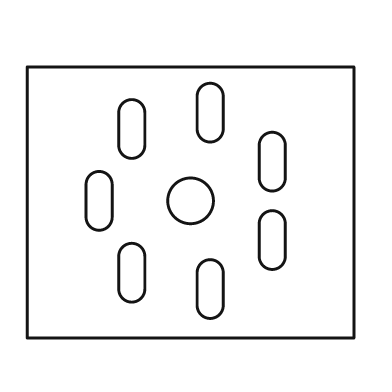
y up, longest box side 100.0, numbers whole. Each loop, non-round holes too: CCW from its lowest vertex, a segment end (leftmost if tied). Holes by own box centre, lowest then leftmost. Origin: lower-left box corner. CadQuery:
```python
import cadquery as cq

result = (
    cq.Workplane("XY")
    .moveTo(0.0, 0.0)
    .lineTo(100.0, 0.0)
    .lineTo(100.0, 83.0)
    .lineTo(0.0, 83.0)
    .close()
    .moveTo(52.0, 10.0)
    .threePointArc((56.0, 6.0), (60.0, 10.0))
    .lineTo(60.0, 20.0)
    .threePointArc((56.0, 24.0), (52.0, 20.0))
    .close()
    .moveTo(28.0, 15.0)
    .threePointArc((32.0, 11.0), (36.0, 15.0))
    .lineTo(36.0, 25.0)
    .threePointArc((32.0, 29.0), (28.0, 25.0))
    .close()
    .moveTo(71.0, 25.0)
    .threePointArc((75.0, 21.0), (79.0, 25.0))
    .lineTo(79.0, 35.0)
    .threePointArc((75.0, 39.0), (71.0, 35.0))
    .close()
    .moveTo(18.0, 37.0)
    .threePointArc((22.0, 33.0), (26.0, 37.0))
    .lineTo(26.0, 47.0)
    .threePointArc((22.0, 51.0), (18.0, 47.0))
    .close()
    .moveTo(50.0, 42.0)
    .circle(7.0)
    .moveTo(71.0, 49.0)
    .threePointArc((75.0, 45.0), (79.0, 49.0))
    .lineTo(79.0, 59.0)
    .threePointArc((75.0, 63.0), (71.0, 59.0))
    .close()
    .moveTo(28.0, 59.0)
    .threePointArc((32.0, 55.0), (36.0, 59.0))
    .lineTo(36.0, 69.0)
    .threePointArc((32.0, 73.0), (28.0, 69.0))
    .close()
    .moveTo(52.0, 64.0)
    .threePointArc((56.0, 60.0), (60.0, 64.0))
    .lineTo(60.0, 74.0)
    .threePointArc((56.0, 78.0), (52.0, 74.0))
    .close()
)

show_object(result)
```